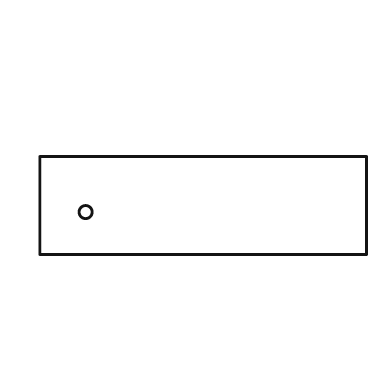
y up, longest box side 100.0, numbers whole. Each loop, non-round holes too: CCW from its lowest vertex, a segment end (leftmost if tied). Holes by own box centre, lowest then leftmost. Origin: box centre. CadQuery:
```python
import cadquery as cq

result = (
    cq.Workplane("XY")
    .moveTo(-50.0, -15.0)
    .lineTo(50.0, -15.0)
    .lineTo(50.0, 15.0)
    .lineTo(-50.0, 15.0)
    .close()
    .moveTo(-36.0, -2.0)
    .circle(2.0)
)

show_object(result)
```